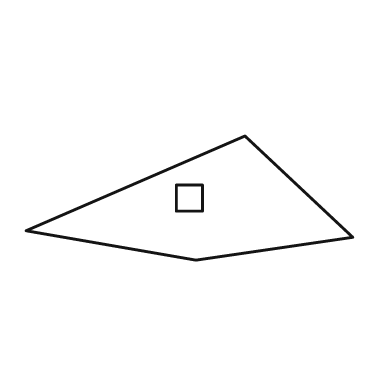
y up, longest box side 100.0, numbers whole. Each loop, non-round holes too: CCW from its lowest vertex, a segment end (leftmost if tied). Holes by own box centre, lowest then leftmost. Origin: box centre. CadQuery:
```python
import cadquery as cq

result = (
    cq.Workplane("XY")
    .moveTo(2.0, -19.0)
    .lineTo(50.0, -12.0)
    .lineTo(17.0, 19.0)
    .lineTo(-50.0, -10.0)
    .close()
    .moveTo(-4.0, -4.0)
    .lineTo(4.0, -4.0)
    .lineTo(4.0, 4.0)
    .lineTo(-4.0, 4.0)
    .close()
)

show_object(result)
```